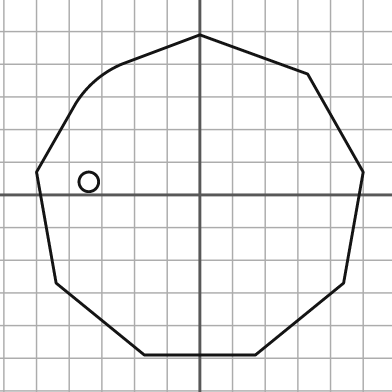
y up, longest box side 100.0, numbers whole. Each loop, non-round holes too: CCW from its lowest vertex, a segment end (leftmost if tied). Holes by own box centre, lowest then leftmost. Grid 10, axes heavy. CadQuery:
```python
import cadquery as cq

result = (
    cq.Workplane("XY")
    .moveTo(-17.0, -49.0)
    .lineTo(17.0, -49.0)
    .lineTo(44.0, -27.0)
    .lineTo(50.0, 7.0)
    .lineTo(33.0, 37.0)
    .lineTo(0.0, 49.0)
    .lineTo(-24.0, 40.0)
    .threePointArc((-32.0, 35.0), (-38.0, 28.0))
    .lineTo(-50.0, 7.0)
    .lineTo(-44.0, -27.0)
    .close()
    .moveTo(-34.0, 4.0)
    .circle(3.0)
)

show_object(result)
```